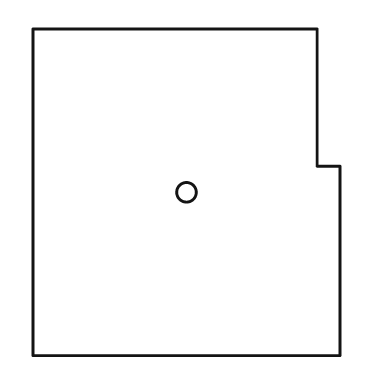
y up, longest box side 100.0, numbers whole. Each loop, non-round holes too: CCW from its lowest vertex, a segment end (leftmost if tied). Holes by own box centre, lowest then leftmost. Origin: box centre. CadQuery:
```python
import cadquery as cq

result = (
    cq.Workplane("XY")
    .moveTo(-47.0, -50.0)
    .lineTo(47.0, -50.0)
    .lineTo(47.0, 8.0)
    .lineTo(40.0, 8.0)
    .lineTo(40.0, 50.0)
    .lineTo(-47.0, 50.0)
    .close()
    .moveTo(0.0, 0.0)
    .circle(3.0)
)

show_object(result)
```